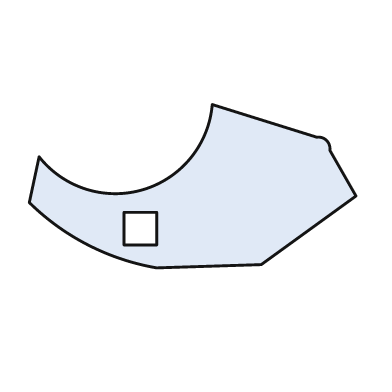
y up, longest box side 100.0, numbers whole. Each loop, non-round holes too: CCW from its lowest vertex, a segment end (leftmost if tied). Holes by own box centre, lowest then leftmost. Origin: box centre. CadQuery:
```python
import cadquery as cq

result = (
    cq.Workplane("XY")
    .moveTo(-11.0, -25.0)
    .lineTo(21.0, -24.0)
    .lineTo(50.0, -3.0)
    .lineTo(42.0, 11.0)
    .threePointArc((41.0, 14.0), (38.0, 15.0))
    .lineTo(6.0, 25.0)
    .threePointArc((-15.0, -1.0), (-47.0, 9.0))
    .lineTo(-50.0, -5.0)
    .threePointArc((-32.0, -18.0), (-11.0, -25.0))
    .close()
    .moveTo(-21.0, -18.0)
    .lineTo(-11.0, -18.0)
    .lineTo(-11.0, -8.0)
    .lineTo(-21.0, -8.0)
    .close()
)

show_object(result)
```